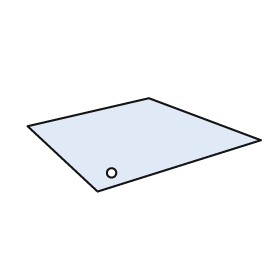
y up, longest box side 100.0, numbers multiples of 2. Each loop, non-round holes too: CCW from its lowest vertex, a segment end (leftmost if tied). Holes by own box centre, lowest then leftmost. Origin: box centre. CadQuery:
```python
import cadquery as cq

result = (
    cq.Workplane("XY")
    .moveTo(-20.0, -20.0)
    .lineTo(50.0, 2.0)
    .lineTo(2.0, 20.0)
    .lineTo(-50.0, 8.0)
    .close()
    .moveTo(-14.0, -12.0)
    .circle(2.0)
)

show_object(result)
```